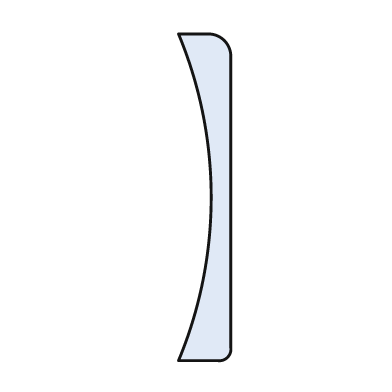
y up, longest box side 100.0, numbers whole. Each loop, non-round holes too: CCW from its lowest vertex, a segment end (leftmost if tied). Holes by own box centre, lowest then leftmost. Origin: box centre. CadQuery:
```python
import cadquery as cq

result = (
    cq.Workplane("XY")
    .moveTo(-8.0, -50.0)
    .lineTo(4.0, -50.0)
    .threePointArc((7.0, -49.0), (8.0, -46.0))
    .lineTo(8.0, 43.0)
    .threePointArc((6.0, 48.0), (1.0, 50.0))
    .lineTo(-8.0, 50.0)
    .threePointArc((2.0, 0.0), (-8.0, -50.0))
    .close()
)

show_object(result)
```